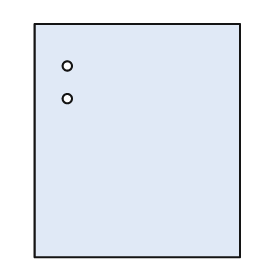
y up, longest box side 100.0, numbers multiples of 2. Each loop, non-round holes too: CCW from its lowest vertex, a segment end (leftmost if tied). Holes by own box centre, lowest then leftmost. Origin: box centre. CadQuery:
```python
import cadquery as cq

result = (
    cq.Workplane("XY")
    .moveTo(-44.0, -50.0)
    .lineTo(44.0, -50.0)
    .lineTo(44.0, 50.0)
    .lineTo(-44.0, 50.0)
    .close()
    .moveTo(-30.0, 18.0)
    .circle(2.0)
    .moveTo(-30.0, 32.0)
    .circle(2.0)
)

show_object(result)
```